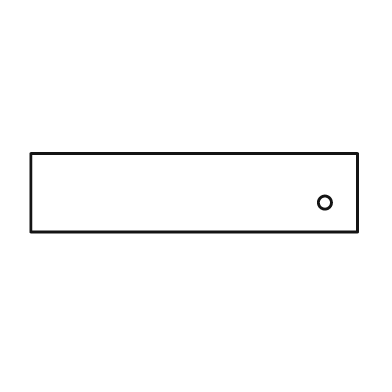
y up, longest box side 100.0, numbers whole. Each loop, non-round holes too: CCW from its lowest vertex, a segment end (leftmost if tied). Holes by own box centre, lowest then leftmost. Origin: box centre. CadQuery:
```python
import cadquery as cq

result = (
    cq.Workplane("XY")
    .moveTo(-50.0, -12.0)
    .lineTo(50.0, -12.0)
    .lineTo(50.0, 12.0)
    .lineTo(-50.0, 12.0)
    .close()
    .moveTo(40.0, -3.0)
    .circle(2.0)
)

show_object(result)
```